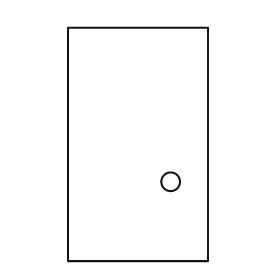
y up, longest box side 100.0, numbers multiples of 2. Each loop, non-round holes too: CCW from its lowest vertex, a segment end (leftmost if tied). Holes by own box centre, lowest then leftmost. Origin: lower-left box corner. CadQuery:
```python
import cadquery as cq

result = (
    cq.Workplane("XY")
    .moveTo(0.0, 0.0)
    .lineTo(60.0, 0.0)
    .lineTo(60.0, 100.0)
    .lineTo(0.0, 100.0)
    .close()
    .moveTo(44.0, 34.0)
    .circle(4.0)
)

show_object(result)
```